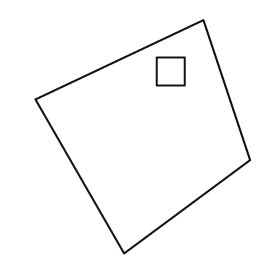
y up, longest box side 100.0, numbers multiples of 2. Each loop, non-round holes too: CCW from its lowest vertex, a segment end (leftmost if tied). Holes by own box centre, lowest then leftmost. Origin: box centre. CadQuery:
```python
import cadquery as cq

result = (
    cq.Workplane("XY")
    .moveTo(-8.0, -50.0)
    .lineTo(46.0, -10.0)
    .lineTo(26.0, 50.0)
    .lineTo(-46.0, 16.0)
    .close()
    .moveTo(6.0, 22.0)
    .lineTo(18.0, 22.0)
    .lineTo(18.0, 34.0)
    .lineTo(6.0, 34.0)
    .close()
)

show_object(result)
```